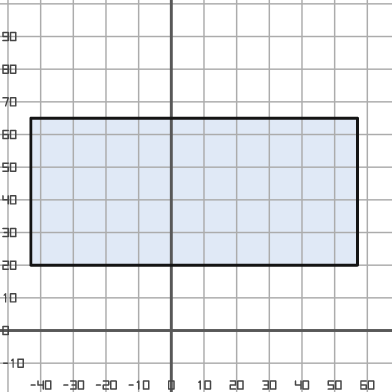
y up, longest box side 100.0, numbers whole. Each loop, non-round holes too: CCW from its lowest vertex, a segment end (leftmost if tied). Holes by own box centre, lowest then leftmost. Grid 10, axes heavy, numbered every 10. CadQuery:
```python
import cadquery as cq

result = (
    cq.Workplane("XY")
    .moveTo(-43.0, 20.0)
    .lineTo(57.0, 20.0)
    .lineTo(57.0, 65.0)
    .lineTo(-43.0, 65.0)
    .close()
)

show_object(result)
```